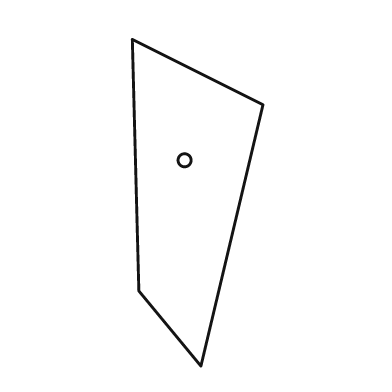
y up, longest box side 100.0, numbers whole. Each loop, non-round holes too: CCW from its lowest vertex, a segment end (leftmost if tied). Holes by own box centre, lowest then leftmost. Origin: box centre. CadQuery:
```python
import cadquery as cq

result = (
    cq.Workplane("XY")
    .moveTo(1.0, -50.0)
    .lineTo(20.0, 30.0)
    .lineTo(-20.0, 50.0)
    .lineTo(-18.0, -27.0)
    .close()
    .moveTo(-4.0, 13.0)
    .circle(2.0)
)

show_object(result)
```